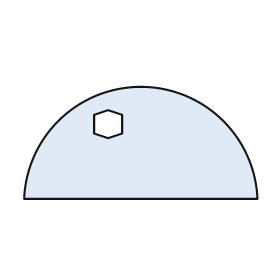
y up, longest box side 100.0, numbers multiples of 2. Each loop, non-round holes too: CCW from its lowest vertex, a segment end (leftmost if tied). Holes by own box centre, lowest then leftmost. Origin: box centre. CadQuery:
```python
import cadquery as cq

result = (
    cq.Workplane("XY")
    .moveTo(-50.0, -24.0)
    .lineTo(50.0, -24.0)
    .threePointArc((0.0, 24.0), (-50.0, -24.0))
    .close()
    .moveTo(-14.0, 2.0)
    .lineTo(-8.0, 4.0)
    .lineTo(-8.0, 12.0)
    .lineTo(-14.0, 14.0)
    .lineTo(-20.0, 12.0)
    .lineTo(-20.0, 4.0)
    .close()
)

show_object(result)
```